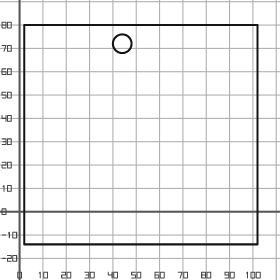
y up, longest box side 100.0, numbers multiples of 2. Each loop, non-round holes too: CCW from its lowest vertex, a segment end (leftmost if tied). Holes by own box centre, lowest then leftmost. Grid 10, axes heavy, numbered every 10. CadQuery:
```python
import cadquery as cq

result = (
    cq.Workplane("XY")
    .moveTo(2.0, -14.0)
    .lineTo(102.0, -14.0)
    .lineTo(102.0, 80.0)
    .lineTo(2.0, 80.0)
    .close()
    .moveTo(44.0, 72.0)
    .circle(4.0)
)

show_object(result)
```